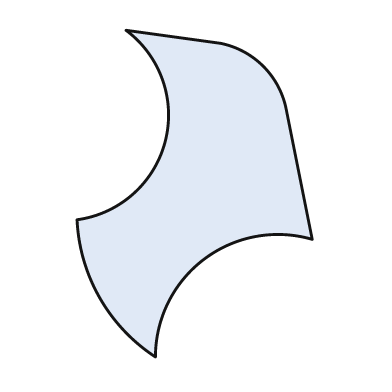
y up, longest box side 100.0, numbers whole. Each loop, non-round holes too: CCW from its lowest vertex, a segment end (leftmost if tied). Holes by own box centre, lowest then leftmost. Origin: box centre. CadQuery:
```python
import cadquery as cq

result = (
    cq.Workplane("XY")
    .moveTo(-12.0, -50.0)
    .threePointArc((3.0, -20.0), (36.0, -14.0))
    .lineTo(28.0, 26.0)
    .threePointArc((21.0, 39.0), (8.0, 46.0))
    .lineTo(-21.0, 50.0)
    .threePointArc((-9.0, 16.0), (-36.0, -8.0))
    .threePointArc((-29.0, -32.0), (-12.0, -50.0))
    .close()
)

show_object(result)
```